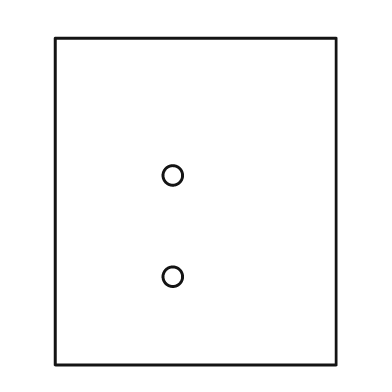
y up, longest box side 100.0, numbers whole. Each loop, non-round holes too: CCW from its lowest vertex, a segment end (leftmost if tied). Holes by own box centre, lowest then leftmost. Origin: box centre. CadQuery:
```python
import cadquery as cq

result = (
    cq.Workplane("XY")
    .moveTo(-43.0, -50.0)
    .lineTo(43.0, -50.0)
    .lineTo(43.0, 50.0)
    .lineTo(-43.0, 50.0)
    .close()
    .moveTo(-7.0, -23.0)
    .circle(3.0)
    .moveTo(-7.0, 8.0)
    .circle(3.0)
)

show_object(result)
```